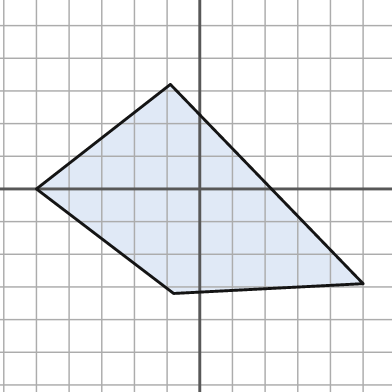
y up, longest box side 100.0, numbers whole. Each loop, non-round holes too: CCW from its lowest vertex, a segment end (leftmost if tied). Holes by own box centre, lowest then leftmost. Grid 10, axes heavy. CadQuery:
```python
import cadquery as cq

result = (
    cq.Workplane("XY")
    .moveTo(-8.0, -32.0)
    .lineTo(50.0, -29.0)
    .lineTo(-9.0, 32.0)
    .lineTo(-50.0, 0.0)
    .close()
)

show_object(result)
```